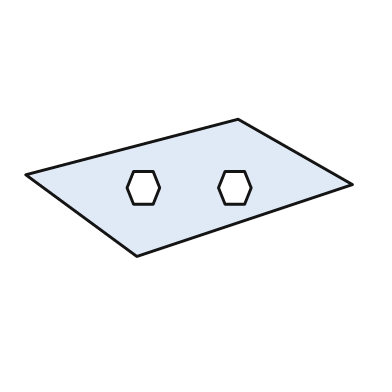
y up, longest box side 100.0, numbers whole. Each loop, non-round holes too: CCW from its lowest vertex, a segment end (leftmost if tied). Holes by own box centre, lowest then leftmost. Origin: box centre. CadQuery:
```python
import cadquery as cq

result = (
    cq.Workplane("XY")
    .moveTo(-16.0, -21.0)
    .lineTo(50.0, 1.0)
    .lineTo(15.0, 21.0)
    .lineTo(-50.0, 4.0)
    .close()
    .moveTo(-17.0, -5.0)
    .lineTo(-11.0, -5.0)
    .lineTo(-9.0, 0.0)
    .lineTo(-11.0, 5.0)
    .lineTo(-17.0, 5.0)
    .lineTo(-19.0, 0.0)
    .close()
    .moveTo(11.0, -5.0)
    .lineTo(17.0, -5.0)
    .lineTo(19.0, 0.0)
    .lineTo(17.0, 5.0)
    .lineTo(11.0, 5.0)
    .lineTo(9.0, 0.0)
    .close()
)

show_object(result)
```